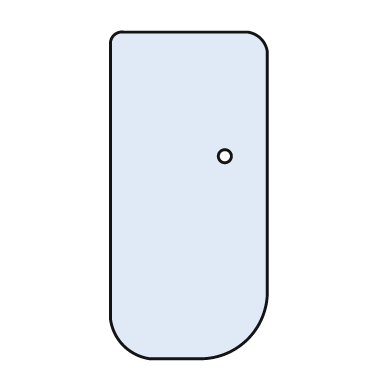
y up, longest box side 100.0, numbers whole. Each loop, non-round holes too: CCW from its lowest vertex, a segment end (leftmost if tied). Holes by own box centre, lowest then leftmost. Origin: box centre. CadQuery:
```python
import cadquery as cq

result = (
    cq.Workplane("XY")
    .moveTo(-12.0, -50.0)
    .lineTo(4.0, -50.0)
    .threePointArc((18.0, -44.0), (24.0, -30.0))
    .lineTo(24.0, 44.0)
    .threePointArc((22.0, 48.0), (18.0, 50.0))
    .lineTo(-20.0, 50.0)
    .threePointArc((-23.0, 49.0), (-24.0, 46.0))
    .lineTo(-24.0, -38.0)
    .threePointArc((-20.0, -46.0), (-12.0, -50.0))
    .close()
    .moveTo(11.0, 12.0)
    .circle(2.0)
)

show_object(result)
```